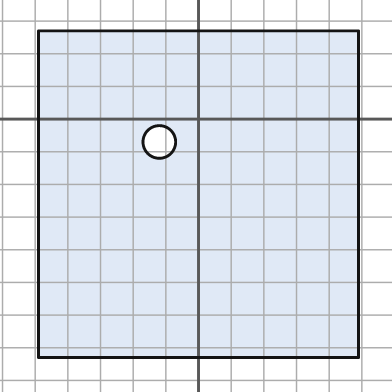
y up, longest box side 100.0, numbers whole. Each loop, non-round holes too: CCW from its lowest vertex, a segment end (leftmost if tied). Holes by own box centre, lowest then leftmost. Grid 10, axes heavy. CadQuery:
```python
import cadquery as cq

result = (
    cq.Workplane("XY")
    .moveTo(-49.0, -73.0)
    .lineTo(49.0, -73.0)
    .lineTo(49.0, 27.0)
    .lineTo(-49.0, 27.0)
    .close()
    .moveTo(-12.0, -7.0)
    .circle(5.0)
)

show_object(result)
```